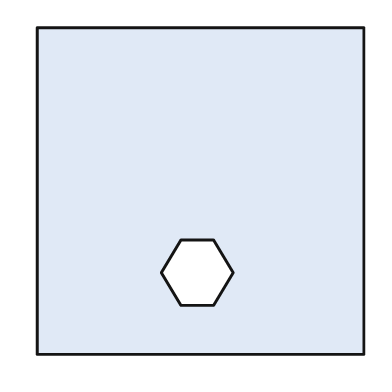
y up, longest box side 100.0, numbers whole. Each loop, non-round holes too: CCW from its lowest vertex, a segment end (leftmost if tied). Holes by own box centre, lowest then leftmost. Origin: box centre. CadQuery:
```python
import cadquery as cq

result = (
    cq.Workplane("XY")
    .moveTo(-50.0, -50.0)
    .lineTo(50.0, -50.0)
    .lineTo(50.0, 50.0)
    .lineTo(-50.0, 50.0)
    .close()
    .moveTo(-6.0, -35.0)
    .lineTo(4.0, -35.0)
    .lineTo(10.0, -25.0)
    .lineTo(4.0, -15.0)
    .lineTo(-6.0, -15.0)
    .lineTo(-12.0, -25.0)
    .close()
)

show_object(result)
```